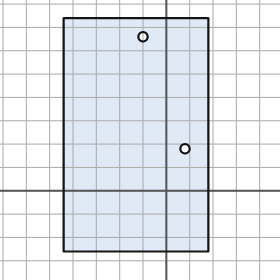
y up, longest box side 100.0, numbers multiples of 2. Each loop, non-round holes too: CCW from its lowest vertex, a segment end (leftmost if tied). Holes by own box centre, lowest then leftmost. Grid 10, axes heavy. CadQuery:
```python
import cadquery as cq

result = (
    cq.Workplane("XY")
    .moveTo(-44.0, -26.0)
    .lineTo(18.0, -26.0)
    .lineTo(18.0, 74.0)
    .lineTo(-44.0, 74.0)
    .close()
    .moveTo(8.0, 18.0)
    .circle(2.0)
    .moveTo(-10.0, 66.0)
    .circle(2.0)
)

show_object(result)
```